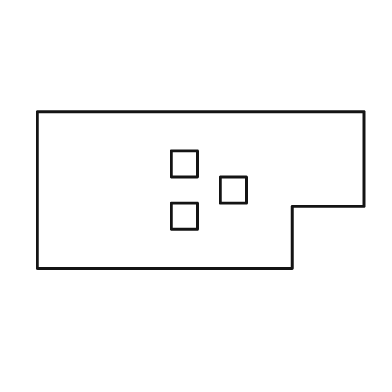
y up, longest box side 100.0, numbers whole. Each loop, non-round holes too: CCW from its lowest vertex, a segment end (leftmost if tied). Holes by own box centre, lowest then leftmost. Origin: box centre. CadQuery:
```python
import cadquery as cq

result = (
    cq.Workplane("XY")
    .moveTo(-50.0, -24.0)
    .lineTo(28.0, -24.0)
    .lineTo(28.0, -5.0)
    .lineTo(50.0, -5.0)
    .lineTo(50.0, 24.0)
    .lineTo(-50.0, 24.0)
    .close()
    .moveTo(-9.0, -12.0)
    .lineTo(-1.0, -12.0)
    .lineTo(-1.0, -4.0)
    .lineTo(-9.0, -4.0)
    .close()
    .moveTo(6.0, -4.0)
    .lineTo(14.0, -4.0)
    .lineTo(14.0, 4.0)
    .lineTo(6.0, 4.0)
    .close()
    .moveTo(-9.0, 4.0)
    .lineTo(-1.0, 4.0)
    .lineTo(-1.0, 12.0)
    .lineTo(-9.0, 12.0)
    .close()
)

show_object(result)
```